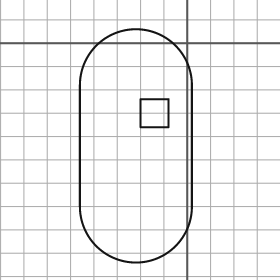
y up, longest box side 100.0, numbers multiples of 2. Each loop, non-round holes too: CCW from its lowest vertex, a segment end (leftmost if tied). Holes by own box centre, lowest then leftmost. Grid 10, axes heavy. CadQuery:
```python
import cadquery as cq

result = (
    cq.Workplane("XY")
    .moveTo(-46.0, -70.0)
    .threePointArc((-22.0, -94.0), (2.0, -70.0))
    .lineTo(2.0, -18.0)
    .threePointArc((-22.0, 6.0), (-46.0, -18.0))
    .close()
    .moveTo(-20.0, -36.0)
    .lineTo(-8.0, -36.0)
    .lineTo(-8.0, -24.0)
    .lineTo(-20.0, -24.0)
    .close()
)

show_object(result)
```